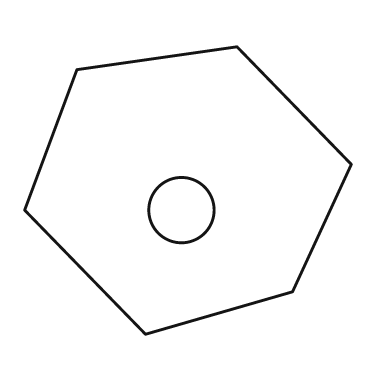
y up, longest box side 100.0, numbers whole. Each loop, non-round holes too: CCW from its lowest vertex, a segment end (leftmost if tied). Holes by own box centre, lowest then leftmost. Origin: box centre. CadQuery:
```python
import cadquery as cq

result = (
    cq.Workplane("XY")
    .moveTo(-13.0, -44.0)
    .lineTo(32.0, -31.0)
    .lineTo(50.0, 8.0)
    .lineTo(15.0, 44.0)
    .lineTo(-34.0, 37.0)
    .lineTo(-50.0, -6.0)
    .close()
    .moveTo(-2.0, -6.0)
    .circle(10.0)
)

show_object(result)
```